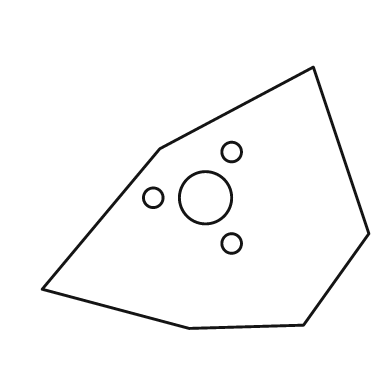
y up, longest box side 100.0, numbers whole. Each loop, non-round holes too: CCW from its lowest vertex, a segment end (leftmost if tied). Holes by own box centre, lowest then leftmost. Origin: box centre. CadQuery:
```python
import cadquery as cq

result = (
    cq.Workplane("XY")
    .moveTo(-5.0, -40.0)
    .lineTo(30.0, -39.0)
    .lineTo(50.0, -11.0)
    .lineTo(33.0, 40.0)
    .lineTo(-14.0, 15.0)
    .lineTo(-50.0, -28.0)
    .close()
    .moveTo(8.0, -14.0)
    .circle(3.0)
    .moveTo(-16.0, 0.0)
    .circle(3.0)
    .moveTo(0.0, 0.0)
    .circle(8.0)
    .moveTo(8.0, 14.0)
    .circle(3.0)
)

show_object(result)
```